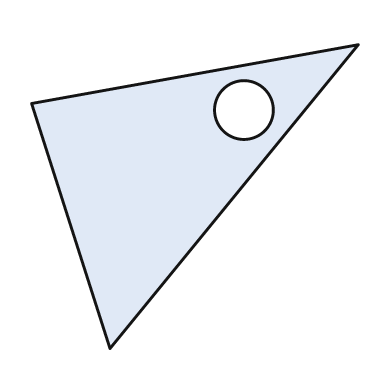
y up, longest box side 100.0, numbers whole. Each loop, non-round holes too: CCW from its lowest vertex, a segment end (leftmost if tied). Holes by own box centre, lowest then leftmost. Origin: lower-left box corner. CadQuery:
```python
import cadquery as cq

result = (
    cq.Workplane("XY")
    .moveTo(24.0, 0.0)
    .lineTo(100.0, 93.0)
    .lineTo(0.0, 75.0)
    .close()
    .moveTo(65.0, 73.0)
    .circle(9.0)
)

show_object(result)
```